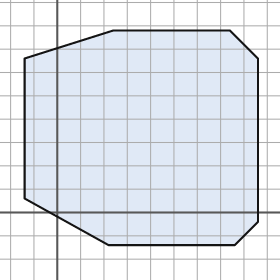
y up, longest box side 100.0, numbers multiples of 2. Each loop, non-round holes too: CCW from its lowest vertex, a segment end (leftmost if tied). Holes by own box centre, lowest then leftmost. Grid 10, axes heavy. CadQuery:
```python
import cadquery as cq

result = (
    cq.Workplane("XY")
    .moveTo(22.0, -14.0)
    .lineTo(76.0, -14.0)
    .lineTo(86.0, -4.0)
    .lineTo(86.0, 66.0)
    .lineTo(74.0, 78.0)
    .lineTo(24.0, 78.0)
    .lineTo(-14.0, 66.0)
    .lineTo(-14.0, 6.0)
    .close()
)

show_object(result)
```